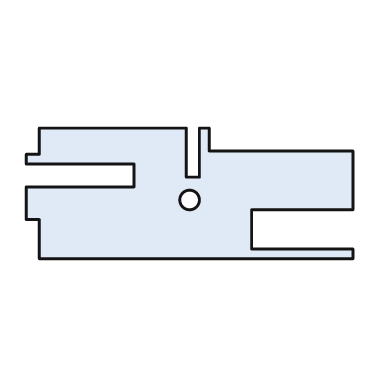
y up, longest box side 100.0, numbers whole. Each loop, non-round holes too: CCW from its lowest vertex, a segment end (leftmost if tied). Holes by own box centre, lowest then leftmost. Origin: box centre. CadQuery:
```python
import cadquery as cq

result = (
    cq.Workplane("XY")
    .moveTo(-46.0, -20.0)
    .lineTo(50.0, -20.0)
    .lineTo(50.0, -17.0)
    .lineTo(19.0, -17.0)
    .lineTo(19.0, -5.0)
    .lineTo(50.0, -5.0)
    .lineTo(50.0, 13.0)
    .lineTo(6.0, 13.0)
    .lineTo(6.0, 20.0)
    .lineTo(3.0, 20.0)
    .lineTo(3.0, 5.0)
    .lineTo(-1.0, 5.0)
    .lineTo(-1.0, 20.0)
    .lineTo(-46.0, 20.0)
    .lineTo(-46.0, 12.0)
    .lineTo(-50.0, 12.0)
    .lineTo(-50.0, 9.0)
    .lineTo(-17.0, 9.0)
    .lineTo(-17.0, 2.0)
    .lineTo(-50.0, 2.0)
    .lineTo(-50.0, -8.0)
    .lineTo(-46.0, -8.0)
    .close()
    .moveTo(0.0, -2.0)
    .circle(3.0)
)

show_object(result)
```